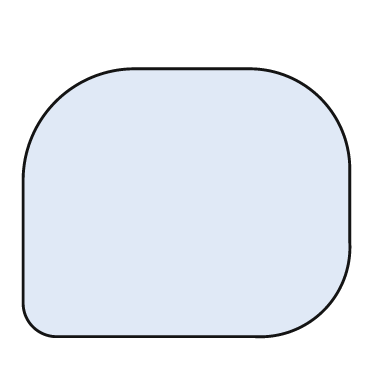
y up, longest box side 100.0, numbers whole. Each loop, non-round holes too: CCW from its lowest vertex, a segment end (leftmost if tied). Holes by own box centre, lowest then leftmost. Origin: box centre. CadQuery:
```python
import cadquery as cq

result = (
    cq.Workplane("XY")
    .moveTo(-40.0, -41.0)
    .lineTo(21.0, -41.0)
    .threePointArc((42.0, -33.0), (50.0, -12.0))
    .lineTo(50.0, 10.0)
    .threePointArc((41.0, 32.0), (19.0, 41.0))
    .lineTo(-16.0, 41.0)
    .threePointArc((-40.0, 31.0), (-50.0, 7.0))
    .lineTo(-50.0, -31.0)
    .threePointArc((-47.0, -38.0), (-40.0, -41.0))
    .close()
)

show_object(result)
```